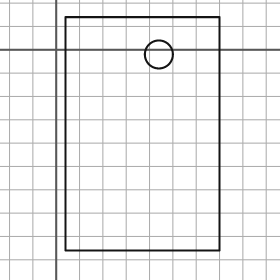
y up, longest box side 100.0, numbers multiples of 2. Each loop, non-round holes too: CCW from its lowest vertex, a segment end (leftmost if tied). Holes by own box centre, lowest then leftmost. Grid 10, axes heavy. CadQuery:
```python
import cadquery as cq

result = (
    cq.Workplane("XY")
    .moveTo(4.0, -86.0)
    .lineTo(70.0, -86.0)
    .lineTo(70.0, 14.0)
    .lineTo(4.0, 14.0)
    .close()
    .moveTo(44.0, -2.0)
    .circle(6.0)
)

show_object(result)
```